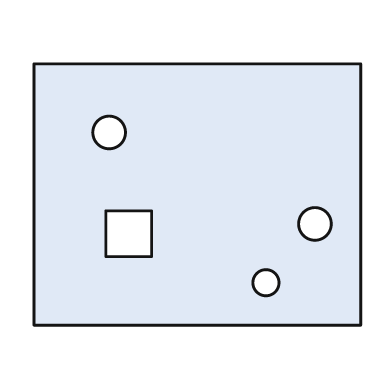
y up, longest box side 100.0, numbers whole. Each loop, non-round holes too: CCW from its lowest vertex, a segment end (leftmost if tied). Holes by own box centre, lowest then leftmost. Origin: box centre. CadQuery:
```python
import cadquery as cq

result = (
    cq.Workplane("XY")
    .moveTo(-50.0, -40.0)
    .lineTo(50.0, -40.0)
    .lineTo(50.0, 40.0)
    .lineTo(-50.0, 40.0)
    .close()
    .moveTo(21.0, -27.0)
    .circle(4.0)
    .moveTo(-28.0, -19.0)
    .lineTo(-14.0, -19.0)
    .lineTo(-14.0, -5.0)
    .lineTo(-28.0, -5.0)
    .close()
    .moveTo(36.0, -9.0)
    .circle(5.0)
    .moveTo(-27.0, 19.0)
    .circle(5.0)
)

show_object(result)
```